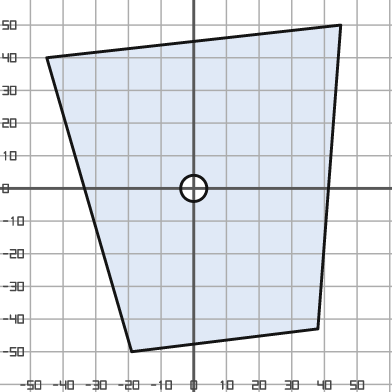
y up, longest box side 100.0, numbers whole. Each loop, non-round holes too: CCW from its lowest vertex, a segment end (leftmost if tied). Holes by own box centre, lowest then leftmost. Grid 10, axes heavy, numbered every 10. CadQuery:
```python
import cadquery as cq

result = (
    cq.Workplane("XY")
    .moveTo(-19.0, -50.0)
    .lineTo(38.0, -43.0)
    .lineTo(45.0, 50.0)
    .lineTo(-45.0, 40.0)
    .close()
    .moveTo(0.0, 0.0)
    .circle(4.0)
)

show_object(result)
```